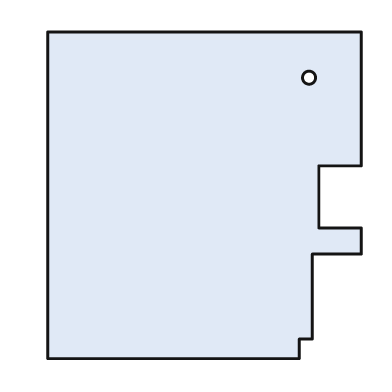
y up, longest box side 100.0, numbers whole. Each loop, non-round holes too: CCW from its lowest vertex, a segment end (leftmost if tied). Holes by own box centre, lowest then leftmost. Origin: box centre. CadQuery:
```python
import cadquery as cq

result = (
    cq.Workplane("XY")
    .moveTo(-48.0, -50.0)
    .lineTo(29.0, -50.0)
    .lineTo(29.0, -44.0)
    .lineTo(33.0, -44.0)
    .lineTo(33.0, -18.0)
    .lineTo(48.0, -18.0)
    .lineTo(48.0, -10.0)
    .lineTo(35.0, -10.0)
    .lineTo(35.0, 9.0)
    .lineTo(48.0, 9.0)
    .lineTo(48.0, 50.0)
    .lineTo(-48.0, 50.0)
    .close()
    .moveTo(32.0, 36.0)
    .circle(2.0)
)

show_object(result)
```